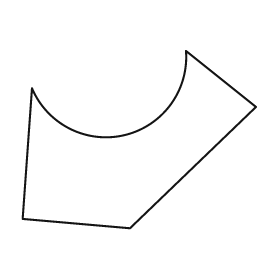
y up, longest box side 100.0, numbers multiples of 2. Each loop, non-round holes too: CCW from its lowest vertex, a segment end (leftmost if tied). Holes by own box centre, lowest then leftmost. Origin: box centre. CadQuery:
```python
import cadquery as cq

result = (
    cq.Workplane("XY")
    .moveTo(-4.0, -38.0)
    .lineTo(50.0, 14.0)
    .lineTo(20.0, 38.0)
    .threePointArc((-6.0, 2.0), (-46.0, 22.0))
    .lineTo(-50.0, -34.0)
    .close()
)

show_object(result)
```